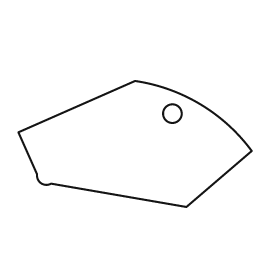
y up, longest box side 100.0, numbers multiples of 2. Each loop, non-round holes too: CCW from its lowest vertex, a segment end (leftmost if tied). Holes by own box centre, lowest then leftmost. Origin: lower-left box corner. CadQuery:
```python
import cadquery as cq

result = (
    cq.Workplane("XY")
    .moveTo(72.0, 0.0)
    .lineTo(100.0, 24.0)
    .threePointArc((78.0, 44.0), (50.0, 54.0))
    .lineTo(0.0, 32.0)
    .lineTo(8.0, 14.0)
    .threePointArc((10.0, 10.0), (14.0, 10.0))
    .close()
    .moveTo(66.0, 40.0)
    .circle(4.0)
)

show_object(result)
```